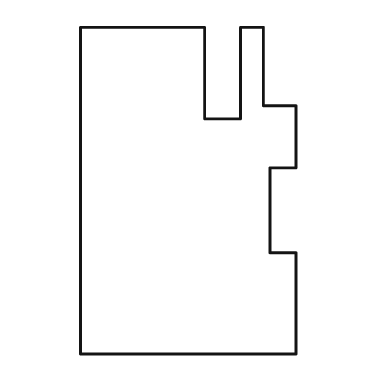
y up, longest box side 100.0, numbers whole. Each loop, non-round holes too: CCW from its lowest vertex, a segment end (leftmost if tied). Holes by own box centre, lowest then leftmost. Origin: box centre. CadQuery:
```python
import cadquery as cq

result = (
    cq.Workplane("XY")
    .moveTo(-33.0, -50.0)
    .lineTo(33.0, -50.0)
    .lineTo(33.0, -19.0)
    .lineTo(25.0, -19.0)
    .lineTo(25.0, 7.0)
    .lineTo(33.0, 7.0)
    .lineTo(33.0, 26.0)
    .lineTo(23.0, 26.0)
    .lineTo(23.0, 50.0)
    .lineTo(16.0, 50.0)
    .lineTo(16.0, 22.0)
    .lineTo(5.0, 22.0)
    .lineTo(5.0, 50.0)
    .lineTo(-33.0, 50.0)
    .close()
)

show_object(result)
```